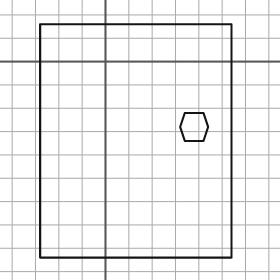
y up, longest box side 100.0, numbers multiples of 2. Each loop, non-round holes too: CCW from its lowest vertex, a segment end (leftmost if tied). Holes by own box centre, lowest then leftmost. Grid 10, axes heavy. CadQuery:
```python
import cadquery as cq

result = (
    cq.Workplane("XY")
    .moveTo(-28.0, -84.0)
    .lineTo(54.0, -84.0)
    .lineTo(54.0, 16.0)
    .lineTo(-28.0, 16.0)
    .close()
    .moveTo(34.0, -34.0)
    .lineTo(42.0, -34.0)
    .lineTo(44.0, -28.0)
    .lineTo(42.0, -22.0)
    .lineTo(34.0, -22.0)
    .lineTo(32.0, -28.0)
    .close()
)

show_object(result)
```